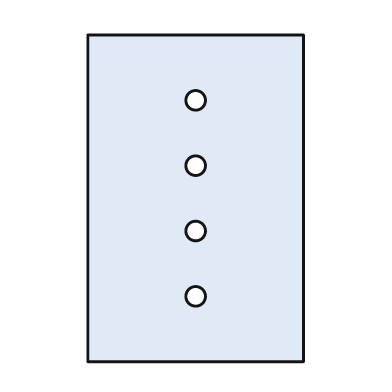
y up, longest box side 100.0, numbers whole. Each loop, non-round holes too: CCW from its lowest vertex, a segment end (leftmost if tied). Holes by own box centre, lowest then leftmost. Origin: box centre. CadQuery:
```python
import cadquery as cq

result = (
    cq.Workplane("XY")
    .moveTo(-33.0, -50.0)
    .lineTo(33.0, -50.0)
    .lineTo(33.0, 50.0)
    .lineTo(-33.0, 50.0)
    .close()
    .moveTo(0.0, -30.0)
    .circle(3.0)
    .moveTo(0.0, -10.0)
    .circle(3.0)
    .moveTo(0.0, 10.0)
    .circle(3.0)
    .moveTo(0.0, 30.0)
    .circle(3.0)
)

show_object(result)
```